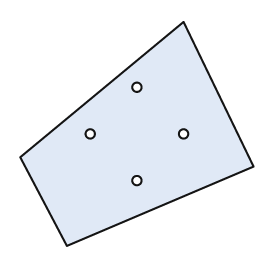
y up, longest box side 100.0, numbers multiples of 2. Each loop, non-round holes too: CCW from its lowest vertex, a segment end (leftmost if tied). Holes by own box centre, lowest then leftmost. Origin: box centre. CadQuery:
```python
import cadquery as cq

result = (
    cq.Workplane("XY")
    .moveTo(-30.0, -48.0)
    .lineTo(50.0, -14.0)
    .lineTo(20.0, 48.0)
    .lineTo(-50.0, -10.0)
    .close()
    .moveTo(0.0, -20.0)
    .circle(2.0)
    .moveTo(-20.0, 0.0)
    .circle(2.0)
    .moveTo(20.0, 0.0)
    .circle(2.0)
    .moveTo(0.0, 20.0)
    .circle(2.0)
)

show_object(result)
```